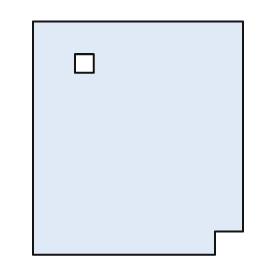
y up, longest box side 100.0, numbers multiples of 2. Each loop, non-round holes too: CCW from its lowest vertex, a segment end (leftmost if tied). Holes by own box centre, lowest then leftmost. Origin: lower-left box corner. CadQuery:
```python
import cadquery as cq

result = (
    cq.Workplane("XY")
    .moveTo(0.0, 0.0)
    .lineTo(78.0, 0.0)
    .lineTo(78.0, 10.0)
    .lineTo(90.0, 10.0)
    .lineTo(90.0, 100.0)
    .lineTo(0.0, 100.0)
    .close()
    .moveTo(18.0, 78.0)
    .lineTo(26.0, 78.0)
    .lineTo(26.0, 86.0)
    .lineTo(18.0, 86.0)
    .close()
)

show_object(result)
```